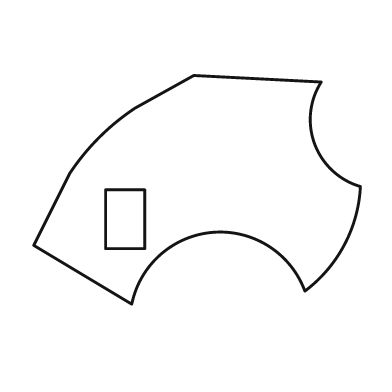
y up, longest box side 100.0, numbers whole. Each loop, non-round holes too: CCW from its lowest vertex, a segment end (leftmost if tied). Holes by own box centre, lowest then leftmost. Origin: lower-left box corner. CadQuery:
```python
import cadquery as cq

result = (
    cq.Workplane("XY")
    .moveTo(30.0, 0.0)
    .threePointArc((55.0, 22.0), (83.0, 4.0))
    .threePointArc((95.0, 18.0), (100.0, 36.0))
    .threePointArc((86.0, 49.0), (88.0, 68.0))
    .lineTo(49.0, 70.0)
    .lineTo(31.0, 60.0)
    .threePointArc((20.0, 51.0), (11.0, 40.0))
    .lineTo(0.0, 18.0)
    .close()
    .moveTo(22.0, 17.0)
    .lineTo(34.0, 17.0)
    .lineTo(34.0, 35.0)
    .lineTo(22.0, 35.0)
    .close()
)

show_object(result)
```